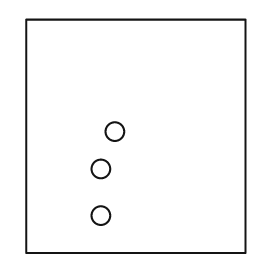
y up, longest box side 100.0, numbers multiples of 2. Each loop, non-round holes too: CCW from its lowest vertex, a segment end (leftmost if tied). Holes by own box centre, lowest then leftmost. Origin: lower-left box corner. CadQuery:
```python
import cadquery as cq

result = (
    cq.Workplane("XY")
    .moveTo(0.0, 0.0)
    .lineTo(94.0, 0.0)
    .lineTo(94.0, 100.0)
    .lineTo(0.0, 100.0)
    .close()
    .moveTo(32.0, 16.0)
    .circle(4.0)
    .moveTo(32.0, 36.0)
    .circle(4.0)
    .moveTo(38.0, 52.0)
    .circle(4.0)
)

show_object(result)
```